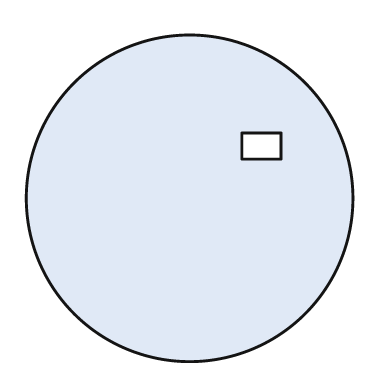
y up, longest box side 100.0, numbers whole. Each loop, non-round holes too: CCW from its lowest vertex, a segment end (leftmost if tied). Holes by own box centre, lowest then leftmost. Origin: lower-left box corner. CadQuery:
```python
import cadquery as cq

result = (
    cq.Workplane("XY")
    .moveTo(50.0, 50.0)
    .circle(50.0)
    .moveTo(66.0, 62.0)
    .lineTo(78.0, 62.0)
    .lineTo(78.0, 70.0)
    .lineTo(66.0, 70.0)
    .close()
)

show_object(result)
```